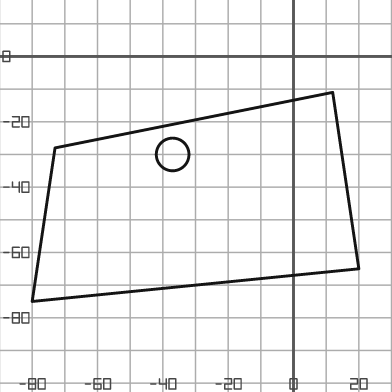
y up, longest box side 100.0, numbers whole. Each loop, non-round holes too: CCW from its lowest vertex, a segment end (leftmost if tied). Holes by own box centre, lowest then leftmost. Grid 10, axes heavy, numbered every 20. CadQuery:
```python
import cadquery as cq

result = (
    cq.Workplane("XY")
    .moveTo(-80.0, -75.0)
    .lineTo(20.0, -65.0)
    .lineTo(12.0, -11.0)
    .lineTo(-73.0, -28.0)
    .close()
    .moveTo(-37.0, -30.0)
    .circle(5.0)
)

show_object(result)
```